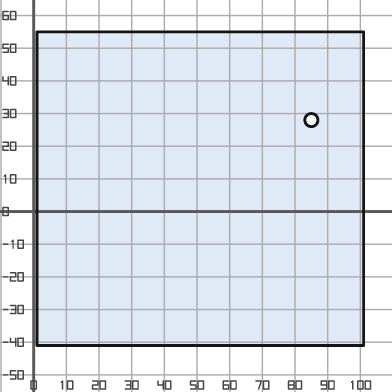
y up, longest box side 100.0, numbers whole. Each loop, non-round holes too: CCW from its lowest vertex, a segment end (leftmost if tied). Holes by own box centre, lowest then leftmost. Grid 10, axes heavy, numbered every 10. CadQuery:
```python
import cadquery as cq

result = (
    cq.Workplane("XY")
    .moveTo(1.0, -41.0)
    .lineTo(101.0, -41.0)
    .lineTo(101.0, 55.0)
    .lineTo(1.0, 55.0)
    .close()
    .moveTo(85.0, 28.0)
    .circle(2.0)
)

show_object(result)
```